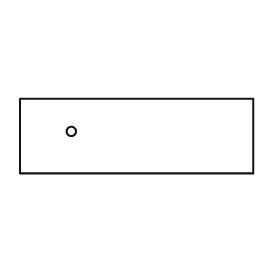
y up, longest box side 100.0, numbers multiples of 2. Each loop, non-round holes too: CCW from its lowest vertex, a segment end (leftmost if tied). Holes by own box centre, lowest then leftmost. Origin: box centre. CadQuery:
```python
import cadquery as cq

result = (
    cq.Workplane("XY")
    .moveTo(-50.0, -16.0)
    .lineTo(50.0, -16.0)
    .lineTo(50.0, 16.0)
    .lineTo(-50.0, 16.0)
    .close()
    .moveTo(-28.0, 2.0)
    .circle(2.0)
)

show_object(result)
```